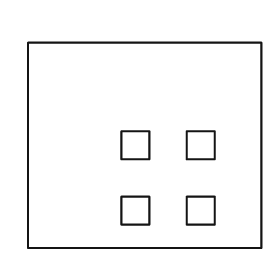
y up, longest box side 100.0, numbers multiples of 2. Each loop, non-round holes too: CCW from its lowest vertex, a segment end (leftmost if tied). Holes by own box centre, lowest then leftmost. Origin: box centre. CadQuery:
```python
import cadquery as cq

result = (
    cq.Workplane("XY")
    .moveTo(-50.0, -44.0)
    .lineTo(50.0, -44.0)
    .lineTo(50.0, 44.0)
    .lineTo(-50.0, 44.0)
    .close()
    .moveTo(-10.0, -34.0)
    .lineTo(2.0, -34.0)
    .lineTo(2.0, -22.0)
    .lineTo(-10.0, -22.0)
    .close()
    .moveTo(18.0, -34.0)
    .lineTo(30.0, -34.0)
    .lineTo(30.0, -22.0)
    .lineTo(18.0, -22.0)
    .close()
    .moveTo(-10.0, -6.0)
    .lineTo(2.0, -6.0)
    .lineTo(2.0, 6.0)
    .lineTo(-10.0, 6.0)
    .close()
    .moveTo(18.0, -6.0)
    .lineTo(30.0, -6.0)
    .lineTo(30.0, 6.0)
    .lineTo(18.0, 6.0)
    .close()
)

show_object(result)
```